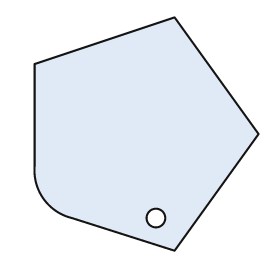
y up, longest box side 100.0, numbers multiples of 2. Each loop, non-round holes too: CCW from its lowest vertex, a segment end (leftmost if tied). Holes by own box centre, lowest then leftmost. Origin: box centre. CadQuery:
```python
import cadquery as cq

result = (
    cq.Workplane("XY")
    .moveTo(12.0, -50.0)
    .lineTo(48.0, 0.0)
    .lineTo(12.0, 50.0)
    .lineTo(-48.0, 30.0)
    .lineTo(-48.0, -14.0)
    .threePointArc((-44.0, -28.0), (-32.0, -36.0))
    .close()
    .moveTo(4.0, -36.0)
    .circle(4.0)
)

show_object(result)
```